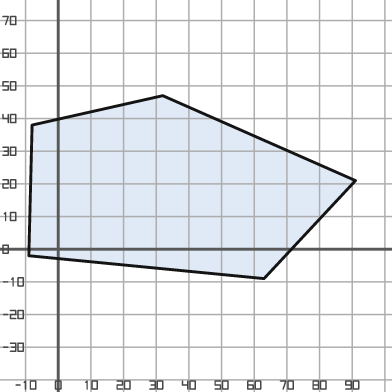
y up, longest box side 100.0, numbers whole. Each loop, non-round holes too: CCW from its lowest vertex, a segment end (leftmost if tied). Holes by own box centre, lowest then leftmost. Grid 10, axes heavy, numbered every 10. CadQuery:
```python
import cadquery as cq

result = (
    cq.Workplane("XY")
    .moveTo(63.0, -9.0)
    .lineTo(91.0, 21.0)
    .lineTo(32.0, 47.0)
    .lineTo(-8.0, 38.0)
    .lineTo(-9.0, -2.0)
    .close()
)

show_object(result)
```